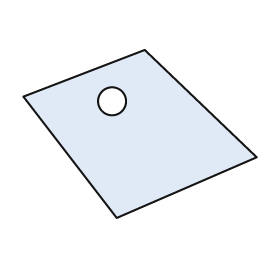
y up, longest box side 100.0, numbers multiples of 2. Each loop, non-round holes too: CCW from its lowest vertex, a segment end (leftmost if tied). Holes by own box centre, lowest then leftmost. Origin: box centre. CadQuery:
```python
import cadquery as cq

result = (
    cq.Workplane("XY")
    .moveTo(-10.0, -36.0)
    .lineTo(50.0, -10.0)
    .lineTo(2.0, 36.0)
    .lineTo(-50.0, 16.0)
    .close()
    .moveTo(-12.0, 14.0)
    .circle(6.0)
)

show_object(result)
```